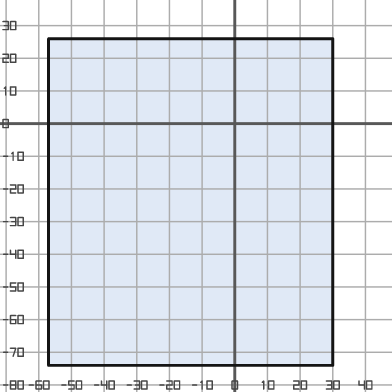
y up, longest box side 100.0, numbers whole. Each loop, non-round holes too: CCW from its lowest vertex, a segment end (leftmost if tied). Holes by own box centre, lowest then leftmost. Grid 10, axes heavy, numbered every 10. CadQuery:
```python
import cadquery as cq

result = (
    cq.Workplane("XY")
    .moveTo(-57.0, -74.0)
    .lineTo(30.0, -74.0)
    .lineTo(30.0, 26.0)
    .lineTo(-57.0, 26.0)
    .close()
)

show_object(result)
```